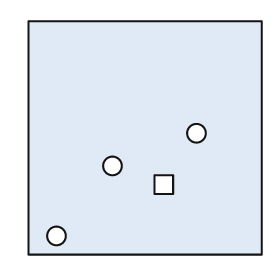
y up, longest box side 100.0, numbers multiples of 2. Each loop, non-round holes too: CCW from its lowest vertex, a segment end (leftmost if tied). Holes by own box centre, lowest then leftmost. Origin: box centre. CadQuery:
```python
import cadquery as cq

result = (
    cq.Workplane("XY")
    .moveTo(-50.0, -50.0)
    .lineTo(50.0, -50.0)
    .lineTo(50.0, 50.0)
    .lineTo(-50.0, 50.0)
    .close()
    .moveTo(-38.0, -42.0)
    .circle(4.0)
    .moveTo(4.0, -24.0)
    .lineTo(12.0, -24.0)
    .lineTo(12.0, -16.0)
    .lineTo(4.0, -16.0)
    .close()
    .moveTo(-14.0, -12.0)
    .circle(4.0)
    .moveTo(22.0, 2.0)
    .circle(4.0)
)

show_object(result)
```